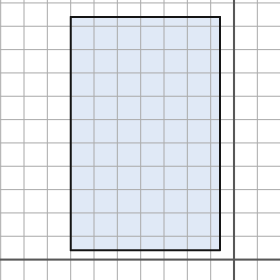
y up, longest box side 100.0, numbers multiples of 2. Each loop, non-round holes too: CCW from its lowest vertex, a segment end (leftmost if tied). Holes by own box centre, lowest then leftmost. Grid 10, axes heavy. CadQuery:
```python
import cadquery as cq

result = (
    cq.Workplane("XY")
    .moveTo(-70.0, 4.0)
    .lineTo(-6.0, 4.0)
    .lineTo(-6.0, 104.0)
    .lineTo(-70.0, 104.0)
    .close()
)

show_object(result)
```